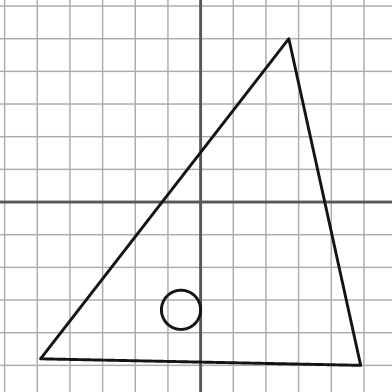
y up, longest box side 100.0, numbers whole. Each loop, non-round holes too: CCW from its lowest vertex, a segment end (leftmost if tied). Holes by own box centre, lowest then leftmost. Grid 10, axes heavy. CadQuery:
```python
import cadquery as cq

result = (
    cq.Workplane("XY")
    .moveTo(49.0, -50.0)
    .lineTo(27.0, 50.0)
    .lineTo(-49.0, -48.0)
    .close()
    .moveTo(-6.0, -33.0)
    .circle(6.0)
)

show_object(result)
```